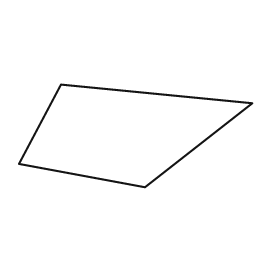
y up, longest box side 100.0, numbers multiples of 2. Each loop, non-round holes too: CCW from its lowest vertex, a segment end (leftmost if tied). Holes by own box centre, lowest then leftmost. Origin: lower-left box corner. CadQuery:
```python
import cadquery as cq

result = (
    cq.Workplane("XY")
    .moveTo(54.0, 0.0)
    .lineTo(100.0, 36.0)
    .lineTo(18.0, 44.0)
    .lineTo(0.0, 10.0)
    .close()
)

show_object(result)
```